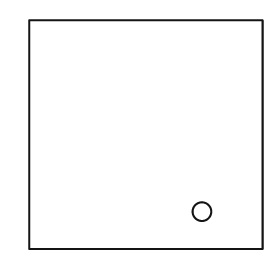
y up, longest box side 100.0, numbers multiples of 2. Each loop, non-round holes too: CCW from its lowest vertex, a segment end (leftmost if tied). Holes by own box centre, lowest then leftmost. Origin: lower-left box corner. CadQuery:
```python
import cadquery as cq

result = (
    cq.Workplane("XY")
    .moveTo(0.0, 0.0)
    .lineTo(100.0, 0.0)
    .lineTo(100.0, 98.0)
    .lineTo(0.0, 98.0)
    .close()
    .moveTo(74.0, 16.0)
    .circle(4.0)
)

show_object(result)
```